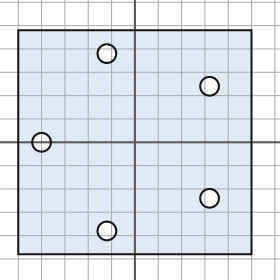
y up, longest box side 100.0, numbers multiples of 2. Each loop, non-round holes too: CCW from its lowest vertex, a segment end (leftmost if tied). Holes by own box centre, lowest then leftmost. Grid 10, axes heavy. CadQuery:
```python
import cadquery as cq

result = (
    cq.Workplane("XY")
    .moveTo(-50.0, -48.0)
    .lineTo(50.0, -48.0)
    .lineTo(50.0, 48.0)
    .lineTo(-50.0, 48.0)
    .close()
    .moveTo(-12.0, -38.0)
    .circle(4.0)
    .moveTo(32.0, -24.0)
    .circle(4.0)
    .moveTo(-40.0, 0.0)
    .circle(4.0)
    .moveTo(32.0, 24.0)
    .circle(4.0)
    .moveTo(-12.0, 38.0)
    .circle(4.0)
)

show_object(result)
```